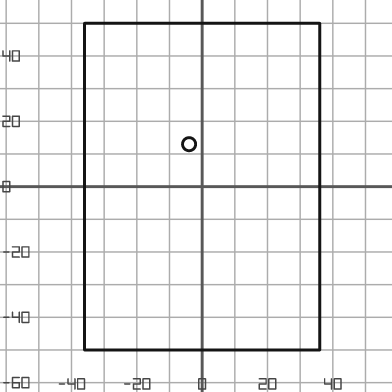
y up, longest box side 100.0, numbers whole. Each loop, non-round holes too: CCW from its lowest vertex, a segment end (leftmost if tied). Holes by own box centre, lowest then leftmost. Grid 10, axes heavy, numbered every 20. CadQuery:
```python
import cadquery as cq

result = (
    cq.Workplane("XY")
    .moveTo(-36.0, -50.0)
    .lineTo(36.0, -50.0)
    .lineTo(36.0, 50.0)
    .lineTo(-36.0, 50.0)
    .close()
    .moveTo(-4.0, 13.0)
    .circle(2.0)
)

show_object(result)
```